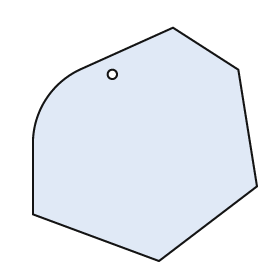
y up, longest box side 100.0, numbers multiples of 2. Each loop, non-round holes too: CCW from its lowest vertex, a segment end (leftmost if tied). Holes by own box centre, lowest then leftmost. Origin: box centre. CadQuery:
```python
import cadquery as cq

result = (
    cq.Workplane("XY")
    .moveTo(6.0, -50.0)
    .lineTo(48.0, -18.0)
    .lineTo(40.0, 32.0)
    .lineTo(12.0, 50.0)
    .lineTo(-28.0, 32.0)
    .threePointArc((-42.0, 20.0), (-48.0, 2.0))
    .lineTo(-48.0, -30.0)
    .close()
    .moveTo(-14.0, 30.0)
    .circle(2.0)
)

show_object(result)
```